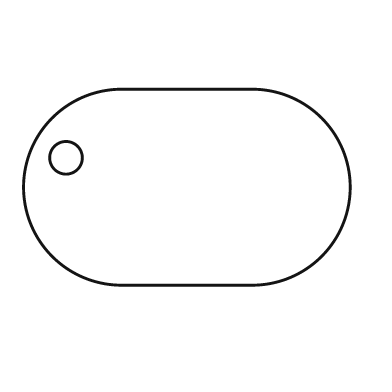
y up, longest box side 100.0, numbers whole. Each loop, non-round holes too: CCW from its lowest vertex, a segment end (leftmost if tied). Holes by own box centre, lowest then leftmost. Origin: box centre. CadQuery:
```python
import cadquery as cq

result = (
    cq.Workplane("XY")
    .moveTo(-20.0, -30.0)
    .lineTo(20.0, -30.0)
    .threePointArc((50.0, 0.0), (20.0, 30.0))
    .lineTo(-20.0, 30.0)
    .threePointArc((-50.0, 0.0), (-20.0, -30.0))
    .close()
    .moveTo(-37.0, 9.0)
    .circle(5.0)
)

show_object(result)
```